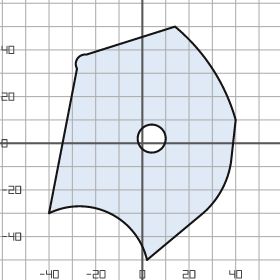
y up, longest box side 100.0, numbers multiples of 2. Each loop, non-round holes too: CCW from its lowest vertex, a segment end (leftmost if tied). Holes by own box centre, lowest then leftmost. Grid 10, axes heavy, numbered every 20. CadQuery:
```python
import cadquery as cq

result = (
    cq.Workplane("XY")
    .moveTo(2.0, -50.0)
    .lineTo(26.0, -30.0)
    .threePointArc((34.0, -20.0), (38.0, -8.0))
    .lineTo(40.0, 10.0)
    .threePointArc((30.0, 32.0), (14.0, 50.0))
    .lineTo(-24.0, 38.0)
    .threePointArc((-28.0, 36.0), (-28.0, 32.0))
    .lineTo(-40.0, -30.0)
    .threePointArc((-14.0, -30.0), (2.0, -50.0))
    .close()
    .moveTo(4.0, 2.0)
    .circle(6.0)
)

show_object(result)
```